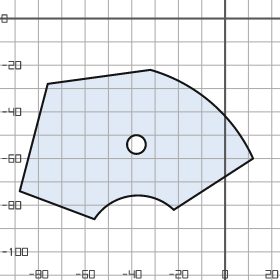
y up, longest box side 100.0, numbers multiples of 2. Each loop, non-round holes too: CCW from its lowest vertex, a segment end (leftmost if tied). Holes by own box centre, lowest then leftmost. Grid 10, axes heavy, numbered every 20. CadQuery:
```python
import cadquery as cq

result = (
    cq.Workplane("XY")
    .moveTo(-56.0, -86.0)
    .threePointArc((-40.0, -76.0), (-22.0, -82.0))
    .lineTo(12.0, -60.0)
    .threePointArc((-6.0, -36.0), (-32.0, -22.0))
    .lineTo(-76.0, -28.0)
    .lineTo(-88.0, -74.0)
    .close()
    .moveTo(-38.0, -54.0)
    .circle(4.0)
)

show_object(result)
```